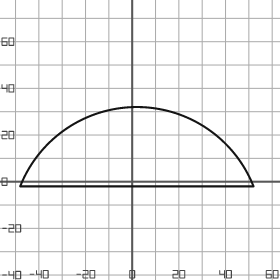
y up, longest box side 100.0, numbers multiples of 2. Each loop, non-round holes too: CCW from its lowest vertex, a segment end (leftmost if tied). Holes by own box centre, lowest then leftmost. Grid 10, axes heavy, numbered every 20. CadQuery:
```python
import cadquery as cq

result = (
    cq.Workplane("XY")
    .moveTo(-48.0, -2.0)
    .lineTo(52.0, -2.0)
    .threePointArc((2.0, 32.0), (-48.0, -2.0))
    .close()
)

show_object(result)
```